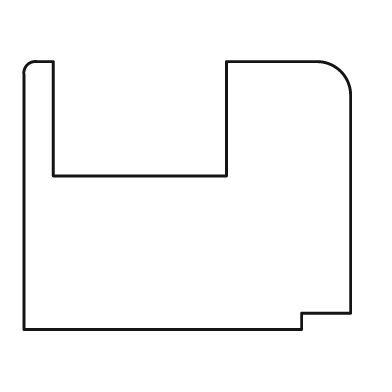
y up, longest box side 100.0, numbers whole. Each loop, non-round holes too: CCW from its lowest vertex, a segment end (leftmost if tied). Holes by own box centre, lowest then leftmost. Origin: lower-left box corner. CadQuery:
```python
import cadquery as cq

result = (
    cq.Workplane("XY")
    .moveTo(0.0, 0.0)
    .lineTo(85.0, 0.0)
    .lineTo(85.0, 5.0)
    .lineTo(100.0, 5.0)
    .lineTo(100.0, 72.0)
    .threePointArc((97.0, 79.0), (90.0, 82.0))
    .lineTo(62.0, 82.0)
    .lineTo(62.0, 47.0)
    .lineTo(9.0, 47.0)
    .lineTo(9.0, 82.0)
    .lineTo(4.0, 82.0)
    .threePointArc((1.0, 81.0), (0.0, 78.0))
    .close()
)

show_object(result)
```